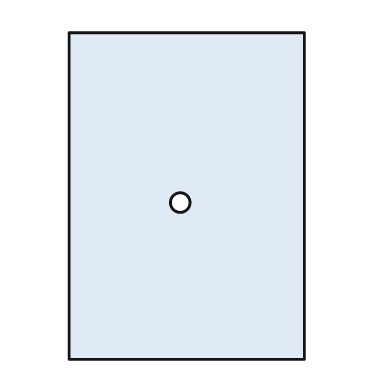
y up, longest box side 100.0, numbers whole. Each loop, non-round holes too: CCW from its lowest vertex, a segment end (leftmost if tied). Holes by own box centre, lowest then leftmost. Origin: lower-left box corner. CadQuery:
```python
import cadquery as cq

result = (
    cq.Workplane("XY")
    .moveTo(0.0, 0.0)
    .lineTo(72.0, 0.0)
    .lineTo(72.0, 100.0)
    .lineTo(0.0, 100.0)
    .close()
    .moveTo(34.0, 48.0)
    .circle(3.0)
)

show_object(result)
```